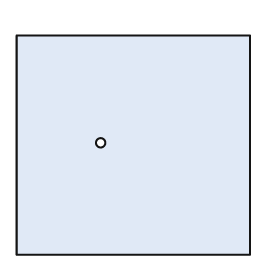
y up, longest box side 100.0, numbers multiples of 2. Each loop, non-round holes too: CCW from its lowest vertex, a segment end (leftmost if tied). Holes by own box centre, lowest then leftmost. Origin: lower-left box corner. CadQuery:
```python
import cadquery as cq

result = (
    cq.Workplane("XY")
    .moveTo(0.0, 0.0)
    .lineTo(100.0, 0.0)
    .lineTo(100.0, 94.0)
    .lineTo(0.0, 94.0)
    .close()
    .moveTo(36.0, 48.0)
    .circle(2.0)
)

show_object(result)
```